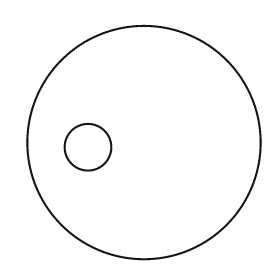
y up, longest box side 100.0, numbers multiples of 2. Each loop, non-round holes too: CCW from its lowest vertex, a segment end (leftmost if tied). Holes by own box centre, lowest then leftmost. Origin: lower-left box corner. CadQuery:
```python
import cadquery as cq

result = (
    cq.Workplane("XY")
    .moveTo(50.0, 50.0)
    .circle(50.0)
    .moveTo(26.0, 48.0)
    .circle(10.0)
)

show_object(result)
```